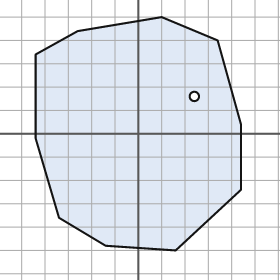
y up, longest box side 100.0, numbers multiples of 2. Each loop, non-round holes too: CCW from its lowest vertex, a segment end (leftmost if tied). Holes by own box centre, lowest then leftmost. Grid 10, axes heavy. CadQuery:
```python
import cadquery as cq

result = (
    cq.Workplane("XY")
    .moveTo(16.0, -50.0)
    .lineTo(44.0, -24.0)
    .lineTo(44.0, 4.0)
    .lineTo(34.0, 40.0)
    .lineTo(10.0, 50.0)
    .lineTo(-26.0, 44.0)
    .lineTo(-44.0, 34.0)
    .lineTo(-44.0, -2.0)
    .lineTo(-34.0, -36.0)
    .lineTo(-14.0, -48.0)
    .close()
    .moveTo(24.0, 16.0)
    .circle(2.0)
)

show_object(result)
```